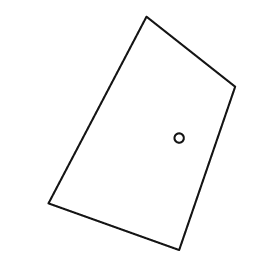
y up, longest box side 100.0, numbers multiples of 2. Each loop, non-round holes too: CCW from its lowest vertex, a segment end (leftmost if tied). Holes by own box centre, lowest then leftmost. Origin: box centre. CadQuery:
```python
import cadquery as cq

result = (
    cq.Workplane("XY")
    .moveTo(16.0, -50.0)
    .lineTo(40.0, 20.0)
    .lineTo(2.0, 50.0)
    .lineTo(-40.0, -30.0)
    .close()
    .moveTo(16.0, -2.0)
    .circle(2.0)
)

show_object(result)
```